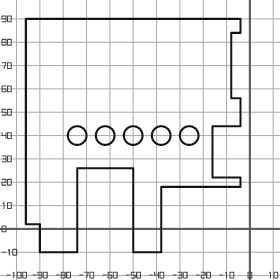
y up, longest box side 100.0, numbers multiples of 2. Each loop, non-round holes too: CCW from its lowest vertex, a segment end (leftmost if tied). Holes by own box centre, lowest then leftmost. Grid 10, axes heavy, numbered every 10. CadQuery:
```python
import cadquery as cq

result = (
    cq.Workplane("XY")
    .moveTo(-90.0, -10.0)
    .lineTo(-74.0, -10.0)
    .lineTo(-74.0, 26.0)
    .lineTo(-50.0, 26.0)
    .lineTo(-50.0, -10.0)
    .lineTo(-38.0, -10.0)
    .lineTo(-38.0, 18.0)
    .lineTo(-4.0, 18.0)
    .lineTo(-4.0, 22.0)
    .lineTo(-16.0, 22.0)
    .lineTo(-16.0, 44.0)
    .lineTo(-4.0, 44.0)
    .lineTo(-4.0, 56.0)
    .lineTo(-8.0, 56.0)
    .lineTo(-8.0, 84.0)
    .lineTo(-4.0, 84.0)
    .lineTo(-4.0, 90.0)
    .lineTo(-96.0, 90.0)
    .lineTo(-96.0, 2.0)
    .lineTo(-90.0, 2.0)
    .close()
    .moveTo(-74.0, 40.0)
    .circle(4.0)
    .moveTo(-62.0, 40.0)
    .circle(4.0)
    .moveTo(-50.0, 40.0)
    .circle(4.0)
    .moveTo(-38.0, 40.0)
    .circle(4.0)
    .moveTo(-26.0, 40.0)
    .circle(4.0)
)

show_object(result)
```